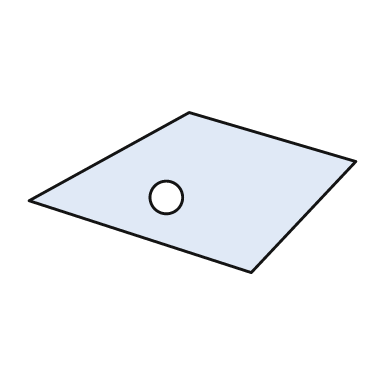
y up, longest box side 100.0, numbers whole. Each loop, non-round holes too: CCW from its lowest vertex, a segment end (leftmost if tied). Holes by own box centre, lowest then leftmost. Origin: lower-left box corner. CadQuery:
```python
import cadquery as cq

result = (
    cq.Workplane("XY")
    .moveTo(68.0, 0.0)
    .lineTo(100.0, 34.0)
    .lineTo(49.0, 49.0)
    .lineTo(0.0, 22.0)
    .close()
    .moveTo(42.0, 23.0)
    .circle(5.0)
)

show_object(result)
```